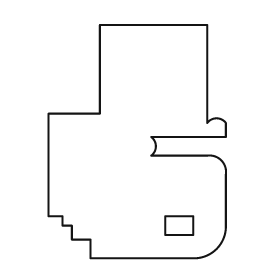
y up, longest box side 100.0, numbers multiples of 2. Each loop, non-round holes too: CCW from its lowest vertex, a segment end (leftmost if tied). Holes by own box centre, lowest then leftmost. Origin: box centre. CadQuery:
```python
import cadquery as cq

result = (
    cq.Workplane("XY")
    .moveTo(-20.0, -50.0)
    .lineTo(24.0, -50.0)
    .threePointArc((34.0, -46.0), (38.0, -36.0))
    .lineTo(38.0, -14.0)
    .threePointArc((36.0, -8.0), (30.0, -6.0))
    .lineTo(6.0, -6.0)
    .threePointArc((8.0, -2.0), (6.0, 2.0))
    .lineTo(38.0, 2.0)
    .lineTo(38.0, 8.0)
    .threePointArc((34.0, 10.0), (30.0, 8.0))
    .lineTo(30.0, 50.0)
    .lineTo(-16.0, 50.0)
    .lineTo(-16.0, 12.0)
    .lineTo(-38.0, 12.0)
    .lineTo(-38.0, -32.0)
    .lineTo(-32.0, -32.0)
    .lineTo(-32.0, -36.0)
    .lineTo(-28.0, -36.0)
    .lineTo(-28.0, -42.0)
    .lineTo(-20.0, -42.0)
    .close()
    .moveTo(12.0, -40.0)
    .lineTo(24.0, -40.0)
    .lineTo(24.0, -32.0)
    .lineTo(12.0, -32.0)
    .close()
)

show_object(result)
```